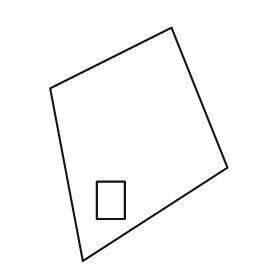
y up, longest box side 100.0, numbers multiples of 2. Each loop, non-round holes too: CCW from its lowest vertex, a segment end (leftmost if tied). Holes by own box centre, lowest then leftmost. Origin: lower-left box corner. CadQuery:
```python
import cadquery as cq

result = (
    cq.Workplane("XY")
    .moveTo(14.0, 0.0)
    .lineTo(76.0, 40.0)
    .lineTo(52.0, 100.0)
    .lineTo(0.0, 74.0)
    .close()
    .moveTo(20.0, 18.0)
    .lineTo(32.0, 18.0)
    .lineTo(32.0, 34.0)
    .lineTo(20.0, 34.0)
    .close()
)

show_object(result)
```